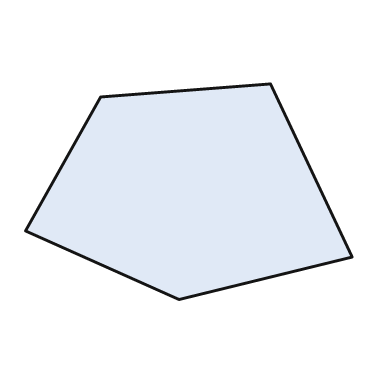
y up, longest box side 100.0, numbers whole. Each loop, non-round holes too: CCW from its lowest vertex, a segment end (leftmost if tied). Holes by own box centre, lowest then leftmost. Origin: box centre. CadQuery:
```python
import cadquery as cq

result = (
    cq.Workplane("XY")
    .moveTo(-3.0, -33.0)
    .lineTo(50.0, -20.0)
    .lineTo(25.0, 33.0)
    .lineTo(-27.0, 29.0)
    .lineTo(-50.0, -12.0)
    .close()
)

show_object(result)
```